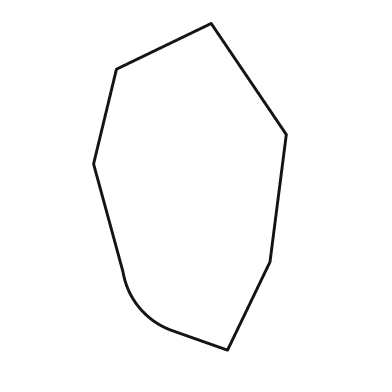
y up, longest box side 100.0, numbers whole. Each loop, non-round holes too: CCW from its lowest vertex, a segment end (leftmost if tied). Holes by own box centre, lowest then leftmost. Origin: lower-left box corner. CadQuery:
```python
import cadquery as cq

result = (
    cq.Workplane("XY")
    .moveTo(41.0, 0.0)
    .lineTo(54.0, 27.0)
    .lineTo(59.0, 66.0)
    .lineTo(36.0, 100.0)
    .lineTo(7.0, 86.0)
    .lineTo(0.0, 57.0)
    .lineTo(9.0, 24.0)
    .threePointArc((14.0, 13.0), (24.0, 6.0))
    .close()
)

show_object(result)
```